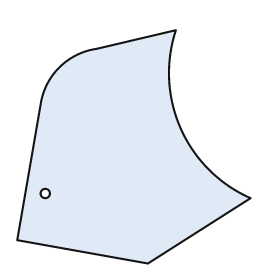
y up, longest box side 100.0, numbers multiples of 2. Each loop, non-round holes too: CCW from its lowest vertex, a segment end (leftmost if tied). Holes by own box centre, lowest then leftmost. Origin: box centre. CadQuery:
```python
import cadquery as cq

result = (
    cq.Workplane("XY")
    .moveTo(6.0, -50.0)
    .lineTo(50.0, -22.0)
    .threePointArc((20.0, 8.0), (18.0, 50.0))
    .lineTo(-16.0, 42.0)
    .threePointArc((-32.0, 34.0), (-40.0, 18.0))
    .lineTo(-50.0, -40.0)
    .close()
    .moveTo(-38.0, -20.0)
    .circle(2.0)
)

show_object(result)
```